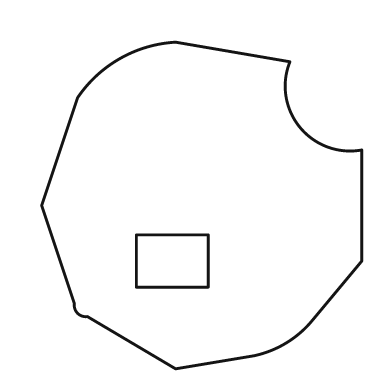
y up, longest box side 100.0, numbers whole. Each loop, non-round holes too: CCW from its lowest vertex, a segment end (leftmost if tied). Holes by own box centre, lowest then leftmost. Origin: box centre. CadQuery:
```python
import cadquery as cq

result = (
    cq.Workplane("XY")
    .moveTo(-8.0, -50.0)
    .lineTo(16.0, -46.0)
    .threePointArc((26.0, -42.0), (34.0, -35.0))
    .lineTo(49.0, -17.0)
    .lineTo(49.0, 17.0)
    .threePointArc((30.0, 24.0), (27.0, 44.0))
    .lineTo(-8.0, 50.0)
    .threePointArc((-25.0, 45.0), (-38.0, 33.0))
    .lineTo(-49.0, 0.0)
    .lineTo(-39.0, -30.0)
    .threePointArc((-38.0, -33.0), (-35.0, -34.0))
    .close()
    .moveTo(-20.0, -25.0)
    .lineTo(2.0, -25.0)
    .lineTo(2.0, -9.0)
    .lineTo(-20.0, -9.0)
    .close()
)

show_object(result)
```